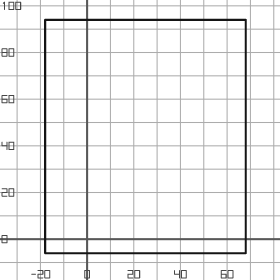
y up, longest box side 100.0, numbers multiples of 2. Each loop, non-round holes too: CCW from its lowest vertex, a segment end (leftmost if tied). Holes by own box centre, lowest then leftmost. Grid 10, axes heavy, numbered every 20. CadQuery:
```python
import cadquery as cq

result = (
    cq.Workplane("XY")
    .moveTo(-18.0, -6.0)
    .lineTo(68.0, -6.0)
    .lineTo(68.0, 94.0)
    .lineTo(-18.0, 94.0)
    .close()
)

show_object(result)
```